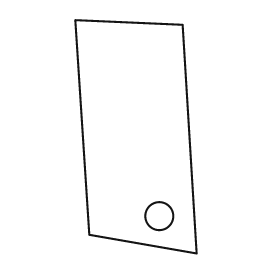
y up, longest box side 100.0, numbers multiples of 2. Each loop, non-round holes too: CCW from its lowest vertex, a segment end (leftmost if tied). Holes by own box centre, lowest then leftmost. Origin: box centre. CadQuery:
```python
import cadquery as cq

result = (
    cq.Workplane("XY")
    .moveTo(26.0, -50.0)
    .lineTo(20.0, 48.0)
    .lineTo(-26.0, 50.0)
    .lineTo(-20.0, -42.0)
    .close()
    .moveTo(10.0, -34.0)
    .circle(6.0)
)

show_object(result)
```